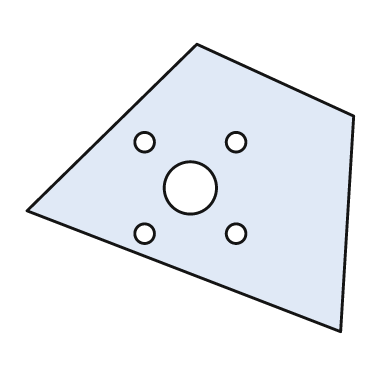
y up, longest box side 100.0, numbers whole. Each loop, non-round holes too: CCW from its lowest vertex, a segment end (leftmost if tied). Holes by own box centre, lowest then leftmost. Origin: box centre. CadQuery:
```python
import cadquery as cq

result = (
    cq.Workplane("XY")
    .moveTo(46.0, -44.0)
    .lineTo(50.0, 22.0)
    .lineTo(2.0, 44.0)
    .lineTo(-50.0, -7.0)
    .close()
    .moveTo(-14.0, -14.0)
    .circle(3.0)
    .moveTo(14.0, -14.0)
    .circle(3.0)
    .moveTo(0.0, 0.0)
    .circle(8.0)
    .moveTo(-14.0, 14.0)
    .circle(3.0)
    .moveTo(14.0, 14.0)
    .circle(3.0)
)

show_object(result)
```